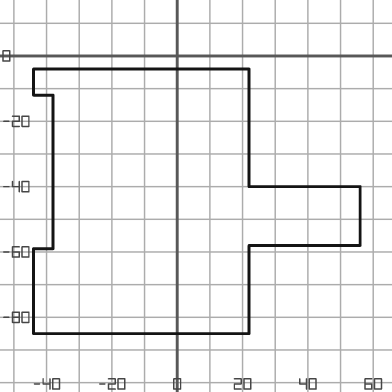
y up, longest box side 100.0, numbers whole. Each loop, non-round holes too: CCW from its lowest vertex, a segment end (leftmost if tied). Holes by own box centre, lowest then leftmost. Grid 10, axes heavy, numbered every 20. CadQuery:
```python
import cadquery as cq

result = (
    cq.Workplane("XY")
    .moveTo(-44.0, -85.0)
    .lineTo(22.0, -85.0)
    .lineTo(22.0, -58.0)
    .lineTo(56.0, -58.0)
    .lineTo(56.0, -40.0)
    .lineTo(22.0, -40.0)
    .lineTo(22.0, -4.0)
    .lineTo(-44.0, -4.0)
    .lineTo(-44.0, -12.0)
    .lineTo(-38.0, -12.0)
    .lineTo(-38.0, -59.0)
    .lineTo(-44.0, -59.0)
    .close()
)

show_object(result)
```